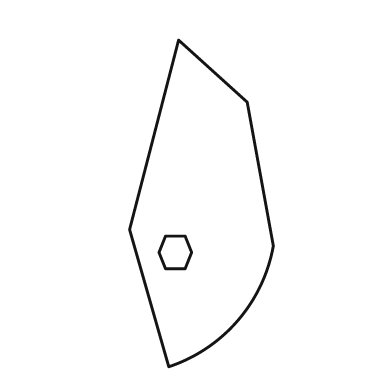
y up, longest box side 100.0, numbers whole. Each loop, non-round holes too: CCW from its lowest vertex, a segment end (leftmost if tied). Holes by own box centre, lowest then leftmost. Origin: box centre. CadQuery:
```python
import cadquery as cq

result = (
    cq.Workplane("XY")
    .moveTo(-10.0, -50.0)
    .threePointArc((11.0, -36.0), (22.0, -13.0))
    .lineTo(14.0, 31.0)
    .lineTo(-7.0, 50.0)
    .lineTo(-22.0, -8.0)
    .close()
    .moveTo(-11.0, -20.0)
    .lineTo(-5.0, -20.0)
    .lineTo(-3.0, -15.0)
    .lineTo(-5.0, -10.0)
    .lineTo(-11.0, -10.0)
    .lineTo(-13.0, -15.0)
    .close()
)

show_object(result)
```